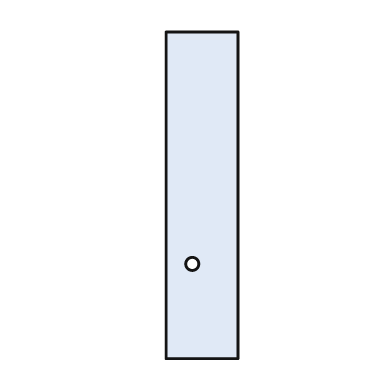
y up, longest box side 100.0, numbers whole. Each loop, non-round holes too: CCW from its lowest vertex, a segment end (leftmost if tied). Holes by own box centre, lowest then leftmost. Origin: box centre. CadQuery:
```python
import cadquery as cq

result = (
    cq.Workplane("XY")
    .moveTo(-11.0, -50.0)
    .lineTo(11.0, -50.0)
    .lineTo(11.0, 50.0)
    .lineTo(-11.0, 50.0)
    .close()
    .moveTo(-3.0, -21.0)
    .circle(2.0)
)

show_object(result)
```